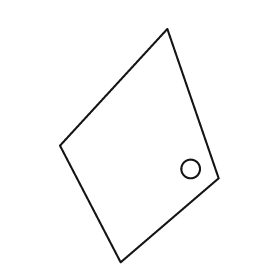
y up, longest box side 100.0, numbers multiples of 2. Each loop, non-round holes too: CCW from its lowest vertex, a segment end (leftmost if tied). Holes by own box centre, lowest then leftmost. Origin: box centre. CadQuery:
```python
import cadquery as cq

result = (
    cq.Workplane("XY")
    .moveTo(-8.0, -50.0)
    .lineTo(34.0, -14.0)
    .lineTo(12.0, 50.0)
    .lineTo(-34.0, 0.0)
    .close()
    .moveTo(22.0, -10.0)
    .circle(4.0)
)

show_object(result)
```